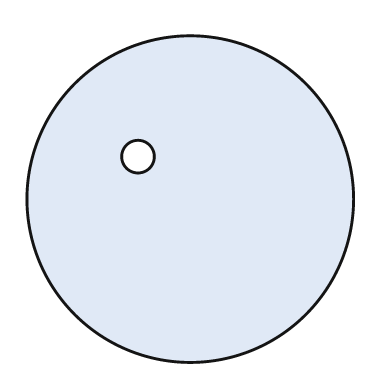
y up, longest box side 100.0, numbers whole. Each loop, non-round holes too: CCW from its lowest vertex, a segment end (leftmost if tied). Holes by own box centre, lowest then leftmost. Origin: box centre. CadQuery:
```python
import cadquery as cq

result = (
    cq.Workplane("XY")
    .moveTo(0.0, 0.0)
    .circle(50.0)
    .moveTo(-16.0, 13.0)
    .circle(5.0)
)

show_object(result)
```